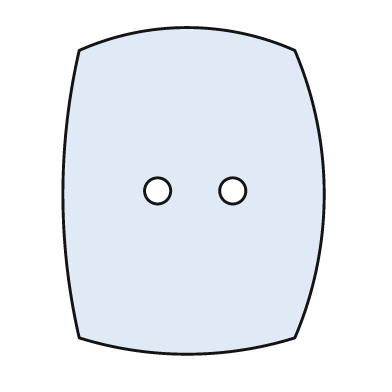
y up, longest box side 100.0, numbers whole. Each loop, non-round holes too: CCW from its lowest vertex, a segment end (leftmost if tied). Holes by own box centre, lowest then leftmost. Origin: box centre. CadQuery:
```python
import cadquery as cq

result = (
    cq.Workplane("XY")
    .moveTo(-35.0, -45.0)
    .threePointArc((-2.0, -50.0), (31.0, -45.0))
    .threePointArc((40.0, -1.0), (31.0, 43.0))
    .threePointArc((-2.0, 50.0), (-35.0, 43.0))
    .threePointArc((-40.0, -1.0), (-35.0, -45.0))
    .close()
    .moveTo(-11.0, 0.0)
    .circle(4.0)
    .moveTo(12.0, 0.0)
    .circle(4.0)
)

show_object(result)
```